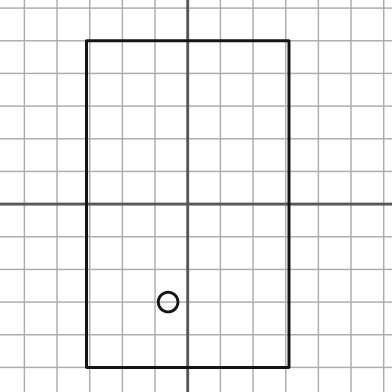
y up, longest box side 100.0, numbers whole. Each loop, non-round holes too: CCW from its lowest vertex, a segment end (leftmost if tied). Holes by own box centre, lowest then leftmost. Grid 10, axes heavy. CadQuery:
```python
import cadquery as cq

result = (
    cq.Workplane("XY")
    .moveTo(-31.0, -50.0)
    .lineTo(31.0, -50.0)
    .lineTo(31.0, 50.0)
    .lineTo(-31.0, 50.0)
    .close()
    .moveTo(-6.0, -30.0)
    .circle(3.0)
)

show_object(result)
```